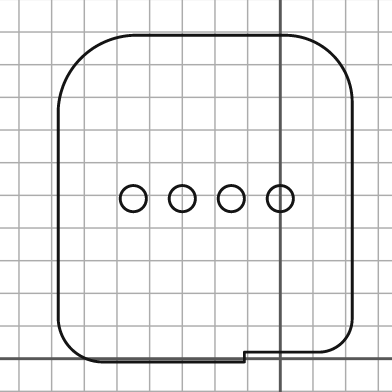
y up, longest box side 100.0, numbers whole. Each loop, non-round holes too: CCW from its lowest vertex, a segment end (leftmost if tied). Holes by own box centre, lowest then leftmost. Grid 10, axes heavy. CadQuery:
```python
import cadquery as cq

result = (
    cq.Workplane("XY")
    .moveTo(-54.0, -1.0)
    .lineTo(-11.0, -1.0)
    .lineTo(-11.0, 2.0)
    .lineTo(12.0, 2.0)
    .threePointArc((19.0, 5.0), (22.0, 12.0))
    .lineTo(22.0, 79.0)
    .threePointArc((16.0, 93.0), (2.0, 99.0))
    .lineTo(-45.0, 99.0)
    .threePointArc((-61.0, 92.0), (-68.0, 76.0))
    .lineTo(-68.0, 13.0)
    .threePointArc((-64.0, 3.0), (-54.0, -1.0))
    .close()
    .moveTo(-45.0, 49.0)
    .circle(4.0)
    .moveTo(-30.0, 49.0)
    .circle(4.0)
    .moveTo(-15.0, 49.0)
    .circle(4.0)
    .moveTo(0.0, 49.0)
    .circle(4.0)
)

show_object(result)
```